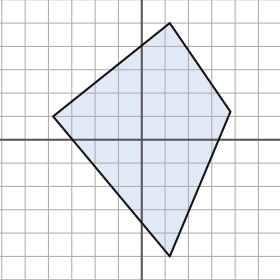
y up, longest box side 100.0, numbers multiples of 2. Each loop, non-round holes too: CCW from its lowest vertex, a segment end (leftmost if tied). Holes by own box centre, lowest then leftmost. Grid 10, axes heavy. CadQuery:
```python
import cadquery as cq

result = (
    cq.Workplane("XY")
    .moveTo(12.0, -50.0)
    .lineTo(38.0, 12.0)
    .lineTo(12.0, 50.0)
    .lineTo(-38.0, 10.0)
    .close()
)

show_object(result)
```